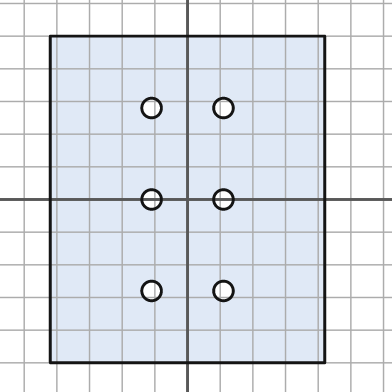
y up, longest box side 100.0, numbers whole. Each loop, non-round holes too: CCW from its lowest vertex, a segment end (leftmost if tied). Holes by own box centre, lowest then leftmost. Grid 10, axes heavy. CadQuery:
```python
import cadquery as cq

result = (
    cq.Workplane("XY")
    .moveTo(-42.0, -50.0)
    .lineTo(42.0, -50.0)
    .lineTo(42.0, 50.0)
    .lineTo(-42.0, 50.0)
    .close()
    .moveTo(-11.0, -28.0)
    .circle(3.0)
    .moveTo(11.0, -28.0)
    .circle(3.0)
    .moveTo(-11.0, 0.0)
    .circle(3.0)
    .moveTo(11.0, 0.0)
    .circle(3.0)
    .moveTo(-11.0, 28.0)
    .circle(3.0)
    .moveTo(11.0, 28.0)
    .circle(3.0)
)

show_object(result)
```